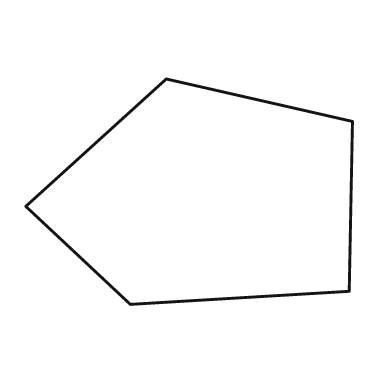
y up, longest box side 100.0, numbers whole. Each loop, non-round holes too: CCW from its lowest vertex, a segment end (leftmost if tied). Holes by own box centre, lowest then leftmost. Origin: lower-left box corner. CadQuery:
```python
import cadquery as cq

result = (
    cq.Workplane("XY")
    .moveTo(32.0, 0.0)
    .lineTo(99.0, 4.0)
    .lineTo(100.0, 56.0)
    .lineTo(43.0, 69.0)
    .lineTo(0.0, 30.0)
    .close()
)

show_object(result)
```